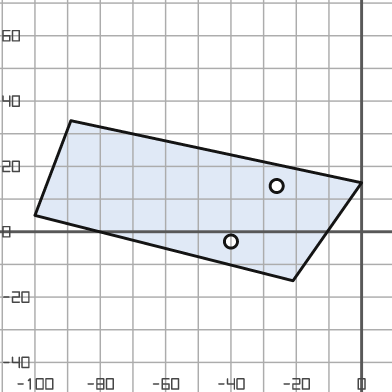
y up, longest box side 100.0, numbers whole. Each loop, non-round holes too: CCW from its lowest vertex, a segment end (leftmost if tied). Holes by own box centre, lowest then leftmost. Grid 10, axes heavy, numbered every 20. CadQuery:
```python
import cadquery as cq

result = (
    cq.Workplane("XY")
    .moveTo(-21.0, -15.0)
    .lineTo(0.0, 15.0)
    .lineTo(-89.0, 34.0)
    .lineTo(-100.0, 5.0)
    .close()
    .moveTo(-40.0, -3.0)
    .circle(2.0)
    .moveTo(-26.0, 14.0)
    .circle(2.0)
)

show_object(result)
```